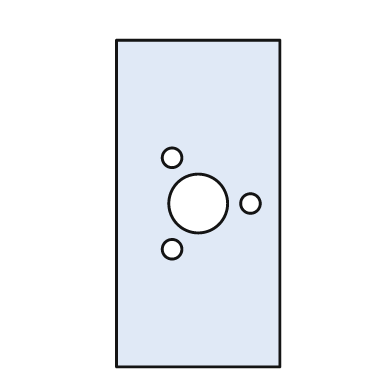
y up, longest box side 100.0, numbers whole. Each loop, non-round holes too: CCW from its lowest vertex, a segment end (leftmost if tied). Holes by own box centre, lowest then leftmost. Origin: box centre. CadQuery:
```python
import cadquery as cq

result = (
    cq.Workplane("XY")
    .moveTo(-25.0, -50.0)
    .lineTo(25.0, -50.0)
    .lineTo(25.0, 50.0)
    .lineTo(-25.0, 50.0)
    .close()
    .moveTo(-8.0, -14.0)
    .circle(3.0)
    .moveTo(0.0, 0.0)
    .circle(9.0)
    .moveTo(16.0, 0.0)
    .circle(3.0)
    .moveTo(-8.0, 14.0)
    .circle(3.0)
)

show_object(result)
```